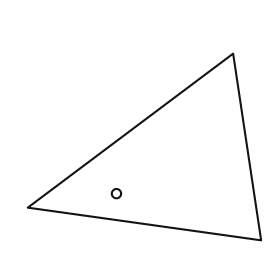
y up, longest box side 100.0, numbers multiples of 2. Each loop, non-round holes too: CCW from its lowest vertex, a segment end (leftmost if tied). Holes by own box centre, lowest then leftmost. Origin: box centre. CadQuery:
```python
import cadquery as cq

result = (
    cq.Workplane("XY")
    .moveTo(50.0, -40.0)
    .lineTo(38.0, 40.0)
    .lineTo(-50.0, -26.0)
    .close()
    .moveTo(-12.0, -20.0)
    .circle(2.0)
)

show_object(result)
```